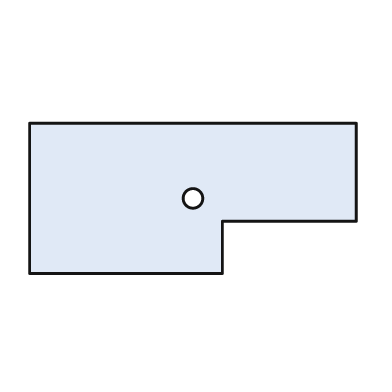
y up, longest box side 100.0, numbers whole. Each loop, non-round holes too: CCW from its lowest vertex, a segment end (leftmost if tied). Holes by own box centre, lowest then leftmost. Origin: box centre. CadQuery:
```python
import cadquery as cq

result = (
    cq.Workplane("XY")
    .moveTo(-50.0, -23.0)
    .lineTo(9.0, -23.0)
    .lineTo(9.0, -7.0)
    .lineTo(50.0, -7.0)
    .lineTo(50.0, 23.0)
    .lineTo(-50.0, 23.0)
    .close()
    .moveTo(0.0, 0.0)
    .circle(3.0)
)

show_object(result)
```